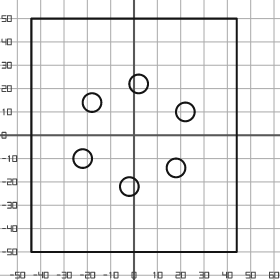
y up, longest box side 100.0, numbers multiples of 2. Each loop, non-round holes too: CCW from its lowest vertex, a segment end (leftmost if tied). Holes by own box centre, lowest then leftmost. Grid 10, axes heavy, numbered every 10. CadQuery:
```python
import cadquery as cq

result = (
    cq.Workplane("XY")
    .moveTo(-44.0, -50.0)
    .lineTo(44.0, -50.0)
    .lineTo(44.0, 50.0)
    .lineTo(-44.0, 50.0)
    .close()
    .moveTo(-2.0, -22.0)
    .circle(4.0)
    .moveTo(18.0, -14.0)
    .circle(4.0)
    .moveTo(-22.0, -10.0)
    .circle(4.0)
    .moveTo(22.0, 10.0)
    .circle(4.0)
    .moveTo(-18.0, 14.0)
    .circle(4.0)
    .moveTo(2.0, 22.0)
    .circle(4.0)
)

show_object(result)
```